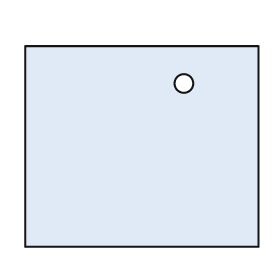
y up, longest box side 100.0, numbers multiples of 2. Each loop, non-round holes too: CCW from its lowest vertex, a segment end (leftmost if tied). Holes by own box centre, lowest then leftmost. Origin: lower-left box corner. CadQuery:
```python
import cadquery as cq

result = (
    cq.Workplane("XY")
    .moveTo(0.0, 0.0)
    .lineTo(100.0, 0.0)
    .lineTo(100.0, 86.0)
    .lineTo(0.0, 86.0)
    .close()
    .moveTo(68.0, 70.0)
    .circle(4.0)
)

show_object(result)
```